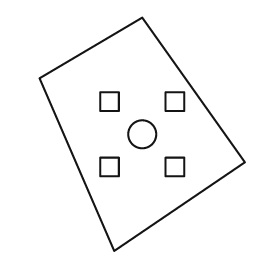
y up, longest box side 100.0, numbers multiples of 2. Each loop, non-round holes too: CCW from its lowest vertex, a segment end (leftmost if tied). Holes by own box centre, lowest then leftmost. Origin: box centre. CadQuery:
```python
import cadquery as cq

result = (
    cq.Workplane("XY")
    .moveTo(-12.0, -50.0)
    .lineTo(44.0, -12.0)
    .lineTo(0.0, 50.0)
    .lineTo(-44.0, 24.0)
    .close()
    .moveTo(-18.0, -18.0)
    .lineTo(-10.0, -18.0)
    .lineTo(-10.0, -10.0)
    .lineTo(-18.0, -10.0)
    .close()
    .moveTo(10.0, -18.0)
    .lineTo(18.0, -18.0)
    .lineTo(18.0, -10.0)
    .lineTo(10.0, -10.0)
    .close()
    .moveTo(0.0, 0.0)
    .circle(6.0)
    .moveTo(-18.0, 10.0)
    .lineTo(-10.0, 10.0)
    .lineTo(-10.0, 18.0)
    .lineTo(-18.0, 18.0)
    .close()
    .moveTo(10.0, 10.0)
    .lineTo(18.0, 10.0)
    .lineTo(18.0, 18.0)
    .lineTo(10.0, 18.0)
    .close()
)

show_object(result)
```